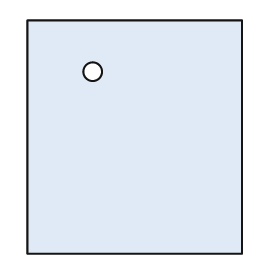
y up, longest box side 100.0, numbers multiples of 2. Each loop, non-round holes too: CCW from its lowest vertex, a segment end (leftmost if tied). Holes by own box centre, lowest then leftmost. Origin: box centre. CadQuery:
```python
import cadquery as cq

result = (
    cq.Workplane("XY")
    .moveTo(-46.0, -50.0)
    .lineTo(46.0, -50.0)
    .lineTo(46.0, 50.0)
    .lineTo(-46.0, 50.0)
    .close()
    .moveTo(-18.0, 28.0)
    .circle(4.0)
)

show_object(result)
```